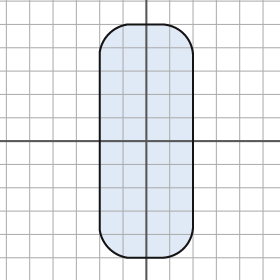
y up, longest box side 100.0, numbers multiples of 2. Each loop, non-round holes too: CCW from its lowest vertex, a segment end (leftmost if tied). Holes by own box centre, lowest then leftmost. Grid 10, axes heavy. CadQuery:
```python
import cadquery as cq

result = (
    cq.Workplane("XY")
    .moveTo(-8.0, -50.0)
    .lineTo(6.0, -50.0)
    .threePointArc((16.0, -46.0), (20.0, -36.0))
    .lineTo(20.0, 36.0)
    .threePointArc((16.0, 46.0), (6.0, 50.0))
    .lineTo(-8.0, 50.0)
    .threePointArc((-16.0, 46.0), (-20.0, 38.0))
    .lineTo(-20.0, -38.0)
    .threePointArc((-16.0, -46.0), (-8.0, -50.0))
    .close()
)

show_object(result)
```